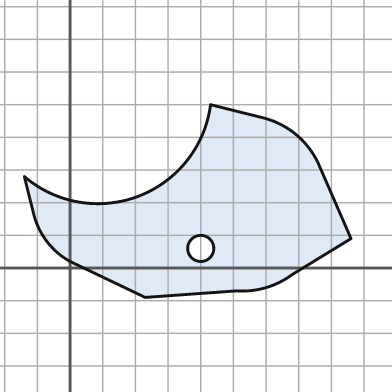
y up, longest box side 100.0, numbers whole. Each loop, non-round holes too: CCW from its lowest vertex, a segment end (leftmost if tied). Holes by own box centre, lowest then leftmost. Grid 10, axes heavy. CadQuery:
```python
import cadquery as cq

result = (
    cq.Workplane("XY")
    .moveTo(23.0, -9.0)
    .lineTo(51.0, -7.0)
    .threePointArc((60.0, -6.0), (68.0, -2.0))
    .lineTo(86.0, 9.0)
    .lineTo(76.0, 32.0)
    .threePointArc((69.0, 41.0), (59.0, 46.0))
    .lineTo(43.0, 50.0)
    .threePointArc((21.0, 22.0), (-14.0, 28.0))
    .lineTo(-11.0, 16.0)
    .threePointArc((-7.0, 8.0), (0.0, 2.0))
    .close()
    .moveTo(40.0, 6.0)
    .circle(4.0)
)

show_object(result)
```